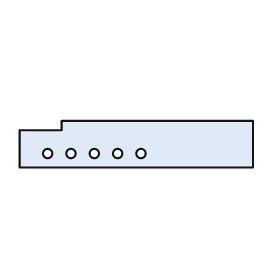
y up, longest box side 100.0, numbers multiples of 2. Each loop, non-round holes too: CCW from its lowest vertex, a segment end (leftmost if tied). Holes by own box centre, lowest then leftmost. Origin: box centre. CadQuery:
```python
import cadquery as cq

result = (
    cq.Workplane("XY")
    .moveTo(-50.0, -10.0)
    .lineTo(50.0, -10.0)
    .lineTo(50.0, 10.0)
    .lineTo(-32.0, 10.0)
    .lineTo(-32.0, 6.0)
    .lineTo(-50.0, 6.0)
    .close()
    .moveTo(-38.0, -4.0)
    .circle(2.0)
    .moveTo(-28.0, -4.0)
    .circle(2.0)
    .moveTo(-18.0, -4.0)
    .circle(2.0)
    .moveTo(-8.0, -4.0)
    .circle(2.0)
    .moveTo(2.0, -4.0)
    .circle(2.0)
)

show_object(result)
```